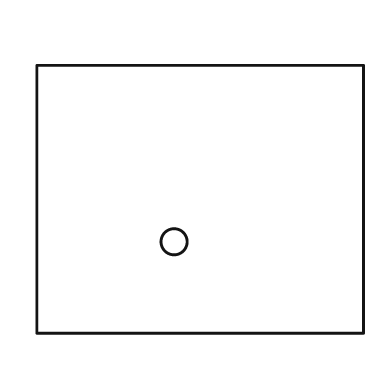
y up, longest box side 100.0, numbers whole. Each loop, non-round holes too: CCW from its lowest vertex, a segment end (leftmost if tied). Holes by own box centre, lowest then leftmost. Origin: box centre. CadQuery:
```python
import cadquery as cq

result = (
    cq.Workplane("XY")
    .moveTo(-50.0, -41.0)
    .lineTo(50.0, -41.0)
    .lineTo(50.0, 41.0)
    .lineTo(-50.0, 41.0)
    .close()
    .moveTo(-8.0, -13.0)
    .circle(4.0)
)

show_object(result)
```